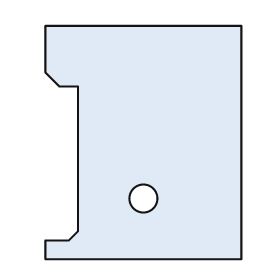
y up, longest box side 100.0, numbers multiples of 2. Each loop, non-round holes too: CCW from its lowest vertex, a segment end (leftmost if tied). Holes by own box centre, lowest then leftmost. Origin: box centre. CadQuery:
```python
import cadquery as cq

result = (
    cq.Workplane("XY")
    .moveTo(-42.0, -50.0)
    .lineTo(42.0, -50.0)
    .lineTo(42.0, 50.0)
    .lineTo(-42.0, 50.0)
    .lineTo(-42.0, 30.0)
    .lineTo(-36.0, 24.0)
    .lineTo(-28.0, 24.0)
    .lineTo(-28.0, -38.0)
    .lineTo(-32.0, -42.0)
    .lineTo(-42.0, -42.0)
    .close()
    .moveTo(0.0, -24.0)
    .circle(6.0)
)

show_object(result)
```